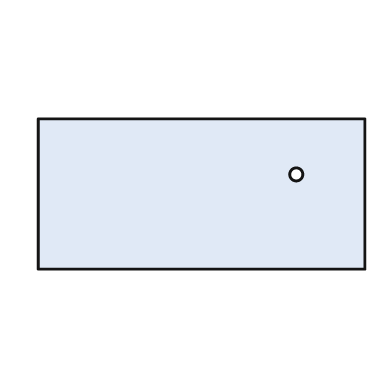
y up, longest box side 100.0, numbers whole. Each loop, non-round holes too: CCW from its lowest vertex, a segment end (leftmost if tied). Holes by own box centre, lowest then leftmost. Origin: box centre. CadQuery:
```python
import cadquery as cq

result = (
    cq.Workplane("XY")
    .moveTo(-50.0, -23.0)
    .lineTo(50.0, -23.0)
    .lineTo(50.0, 23.0)
    .lineTo(-50.0, 23.0)
    .close()
    .moveTo(29.0, 6.0)
    .circle(2.0)
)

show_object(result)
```